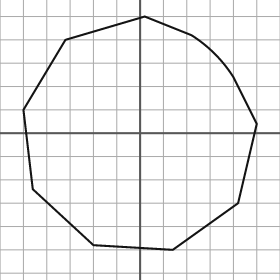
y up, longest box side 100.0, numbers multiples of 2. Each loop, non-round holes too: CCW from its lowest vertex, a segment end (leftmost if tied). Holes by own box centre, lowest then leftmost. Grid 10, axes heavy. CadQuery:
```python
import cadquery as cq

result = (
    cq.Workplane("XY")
    .moveTo(14.0, -50.0)
    .lineTo(42.0, -30.0)
    .lineTo(50.0, 4.0)
    .lineTo(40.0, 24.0)
    .threePointArc((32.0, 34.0), (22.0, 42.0))
    .lineTo(2.0, 50.0)
    .lineTo(-32.0, 40.0)
    .lineTo(-50.0, 10.0)
    .lineTo(-46.0, -24.0)
    .lineTo(-20.0, -48.0)
    .close()
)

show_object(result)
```